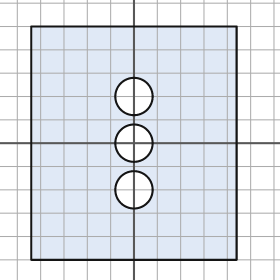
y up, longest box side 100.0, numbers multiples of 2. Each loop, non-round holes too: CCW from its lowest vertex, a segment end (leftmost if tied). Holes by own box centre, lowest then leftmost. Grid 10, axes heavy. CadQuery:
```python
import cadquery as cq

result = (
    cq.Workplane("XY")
    .moveTo(-44.0, -50.0)
    .lineTo(44.0, -50.0)
    .lineTo(44.0, 50.0)
    .lineTo(-44.0, 50.0)
    .close()
    .moveTo(0.0, -20.0)
    .circle(8.0)
    .moveTo(0.0, 0.0)
    .circle(8.0)
    .moveTo(0.0, 20.0)
    .circle(8.0)
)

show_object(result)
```